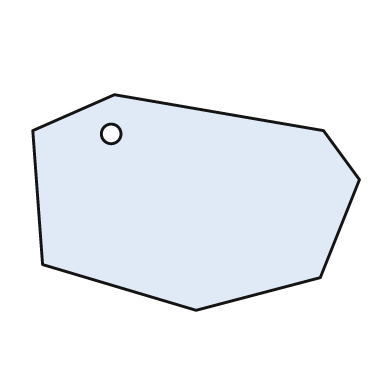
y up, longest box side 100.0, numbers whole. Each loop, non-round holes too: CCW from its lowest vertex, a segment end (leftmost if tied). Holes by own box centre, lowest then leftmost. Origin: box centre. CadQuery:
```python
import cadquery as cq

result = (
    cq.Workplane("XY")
    .moveTo(0.0, -33.0)
    .lineTo(38.0, -23.0)
    .lineTo(50.0, 7.0)
    .lineTo(39.0, 22.0)
    .lineTo(-25.0, 33.0)
    .lineTo(-50.0, 22.0)
    .lineTo(-47.0, -19.0)
    .close()
    .moveTo(-26.0, 21.0)
    .circle(3.0)
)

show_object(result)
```